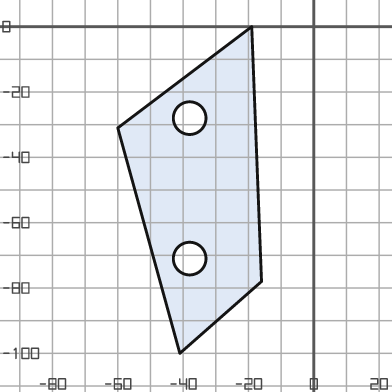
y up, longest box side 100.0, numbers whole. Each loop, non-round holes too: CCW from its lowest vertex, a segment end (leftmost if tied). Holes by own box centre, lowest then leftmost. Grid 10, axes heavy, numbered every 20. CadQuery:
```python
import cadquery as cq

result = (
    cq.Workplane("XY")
    .moveTo(-41.0, -100.0)
    .lineTo(-16.0, -78.0)
    .lineTo(-19.0, 0.0)
    .lineTo(-60.0, -31.0)
    .close()
    .moveTo(-38.0, -71.0)
    .circle(5.0)
    .moveTo(-38.0, -28.0)
    .circle(5.0)
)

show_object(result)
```